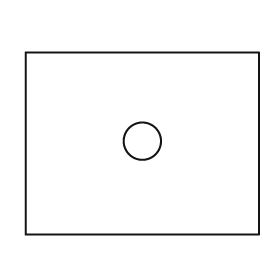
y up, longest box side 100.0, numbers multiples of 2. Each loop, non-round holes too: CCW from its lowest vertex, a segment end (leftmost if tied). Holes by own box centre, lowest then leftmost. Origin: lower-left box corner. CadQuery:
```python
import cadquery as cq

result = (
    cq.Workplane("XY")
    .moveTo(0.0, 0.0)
    .lineTo(100.0, 0.0)
    .lineTo(100.0, 78.0)
    .lineTo(0.0, 78.0)
    .close()
    .moveTo(50.0, 40.0)
    .circle(8.0)
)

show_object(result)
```